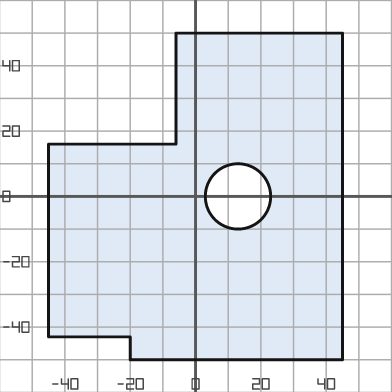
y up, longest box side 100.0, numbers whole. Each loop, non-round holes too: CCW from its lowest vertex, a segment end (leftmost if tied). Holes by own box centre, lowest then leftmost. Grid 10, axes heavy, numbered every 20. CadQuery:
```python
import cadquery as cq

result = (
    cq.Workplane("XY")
    .moveTo(-20.0, -50.0)
    .lineTo(45.0, -50.0)
    .lineTo(45.0, 50.0)
    .lineTo(-6.0, 50.0)
    .lineTo(-6.0, 16.0)
    .lineTo(-45.0, 16.0)
    .lineTo(-45.0, -43.0)
    .lineTo(-20.0, -43.0)
    .close()
    .moveTo(13.0, 0.0)
    .circle(10.0)
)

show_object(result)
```